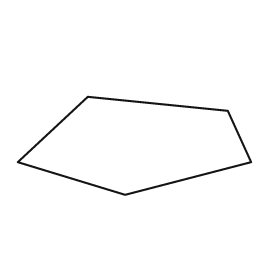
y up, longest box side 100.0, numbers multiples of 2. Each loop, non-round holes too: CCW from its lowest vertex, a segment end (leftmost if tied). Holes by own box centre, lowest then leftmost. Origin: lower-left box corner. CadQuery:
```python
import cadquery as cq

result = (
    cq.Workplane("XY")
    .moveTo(46.0, 0.0)
    .lineTo(100.0, 14.0)
    .lineTo(90.0, 36.0)
    .lineTo(30.0, 42.0)
    .lineTo(0.0, 14.0)
    .close()
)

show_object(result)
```